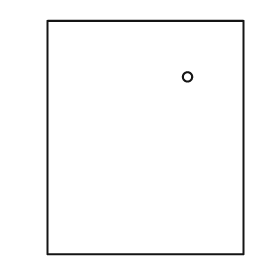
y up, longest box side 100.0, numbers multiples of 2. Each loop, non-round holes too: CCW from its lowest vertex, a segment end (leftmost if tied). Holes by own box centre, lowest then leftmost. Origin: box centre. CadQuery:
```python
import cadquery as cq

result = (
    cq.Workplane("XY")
    .moveTo(-42.0, -50.0)
    .lineTo(42.0, -50.0)
    .lineTo(42.0, 50.0)
    .lineTo(-42.0, 50.0)
    .close()
    .moveTo(18.0, 26.0)
    .circle(2.0)
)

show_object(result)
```